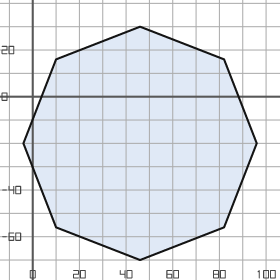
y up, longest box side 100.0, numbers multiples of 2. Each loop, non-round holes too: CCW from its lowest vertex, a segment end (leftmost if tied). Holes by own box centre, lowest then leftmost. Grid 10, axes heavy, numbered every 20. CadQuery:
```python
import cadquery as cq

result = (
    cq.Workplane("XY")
    .moveTo(46.0, -70.0)
    .lineTo(82.0, -56.0)
    .lineTo(96.0, -20.0)
    .lineTo(82.0, 16.0)
    .lineTo(46.0, 30.0)
    .lineTo(10.0, 16.0)
    .lineTo(-4.0, -20.0)
    .lineTo(10.0, -56.0)
    .close()
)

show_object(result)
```